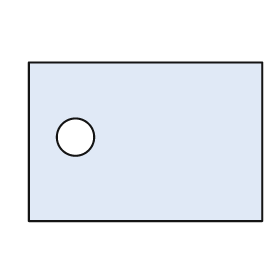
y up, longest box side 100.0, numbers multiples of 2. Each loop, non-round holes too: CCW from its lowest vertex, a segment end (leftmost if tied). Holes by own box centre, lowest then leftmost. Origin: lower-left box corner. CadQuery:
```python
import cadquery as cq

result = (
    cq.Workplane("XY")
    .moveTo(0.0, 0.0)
    .lineTo(100.0, 0.0)
    .lineTo(100.0, 68.0)
    .lineTo(0.0, 68.0)
    .close()
    .moveTo(20.0, 36.0)
    .circle(8.0)
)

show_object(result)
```